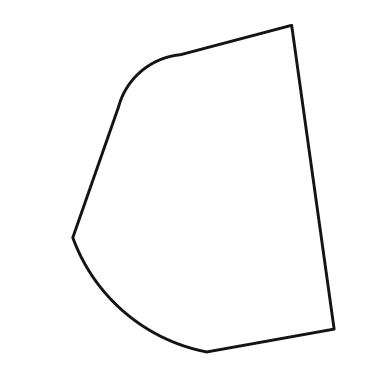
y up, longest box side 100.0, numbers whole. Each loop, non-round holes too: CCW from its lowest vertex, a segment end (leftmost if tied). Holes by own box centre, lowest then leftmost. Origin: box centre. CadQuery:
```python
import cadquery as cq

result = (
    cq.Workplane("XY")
    .moveTo(1.0, -50.0)
    .lineTo(40.0, -43.0)
    .lineTo(27.0, 50.0)
    .lineTo(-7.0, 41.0)
    .threePointArc((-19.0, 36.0), (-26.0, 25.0))
    .lineTo(-40.0, -15.0)
    .threePointArc((-24.0, -38.0), (1.0, -50.0))
    .close()
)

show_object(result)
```